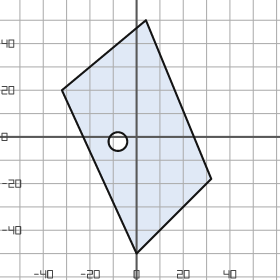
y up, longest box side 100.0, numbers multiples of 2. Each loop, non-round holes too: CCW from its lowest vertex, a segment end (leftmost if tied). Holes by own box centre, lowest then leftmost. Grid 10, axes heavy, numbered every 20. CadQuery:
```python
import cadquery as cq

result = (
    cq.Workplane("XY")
    .moveTo(0.0, -50.0)
    .lineTo(32.0, -18.0)
    .lineTo(4.0, 50.0)
    .lineTo(-32.0, 20.0)
    .close()
    .moveTo(-8.0, -2.0)
    .circle(4.0)
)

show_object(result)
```